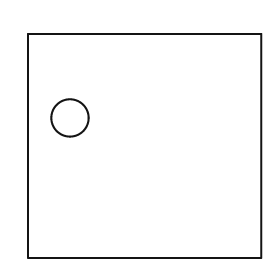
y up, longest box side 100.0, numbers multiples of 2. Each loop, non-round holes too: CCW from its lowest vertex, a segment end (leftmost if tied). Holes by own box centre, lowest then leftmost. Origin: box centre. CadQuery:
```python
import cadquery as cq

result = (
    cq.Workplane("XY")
    .moveTo(-50.0, -48.0)
    .lineTo(50.0, -48.0)
    .lineTo(50.0, 48.0)
    .lineTo(-50.0, 48.0)
    .close()
    .moveTo(-32.0, 12.0)
    .circle(8.0)
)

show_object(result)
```